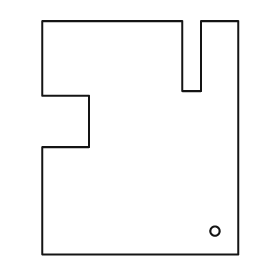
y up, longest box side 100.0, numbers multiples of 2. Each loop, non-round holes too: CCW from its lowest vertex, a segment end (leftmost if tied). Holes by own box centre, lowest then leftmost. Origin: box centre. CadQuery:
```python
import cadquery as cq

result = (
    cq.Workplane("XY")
    .moveTo(-42.0, -50.0)
    .lineTo(42.0, -50.0)
    .lineTo(42.0, 50.0)
    .lineTo(26.0, 50.0)
    .lineTo(26.0, 20.0)
    .lineTo(18.0, 20.0)
    .lineTo(18.0, 50.0)
    .lineTo(-42.0, 50.0)
    .lineTo(-42.0, 18.0)
    .lineTo(-22.0, 18.0)
    .lineTo(-22.0, -4.0)
    .lineTo(-42.0, -4.0)
    .close()
    .moveTo(32.0, -40.0)
    .circle(2.0)
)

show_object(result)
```